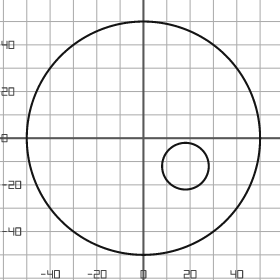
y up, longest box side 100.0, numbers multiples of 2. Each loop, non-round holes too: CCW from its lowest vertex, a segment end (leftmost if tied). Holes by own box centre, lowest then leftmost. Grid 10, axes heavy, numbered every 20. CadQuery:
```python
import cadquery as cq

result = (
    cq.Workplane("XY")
    .moveTo(0.0, 0.0)
    .circle(50.0)
    .moveTo(18.0, -12.0)
    .circle(10.0)
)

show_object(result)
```